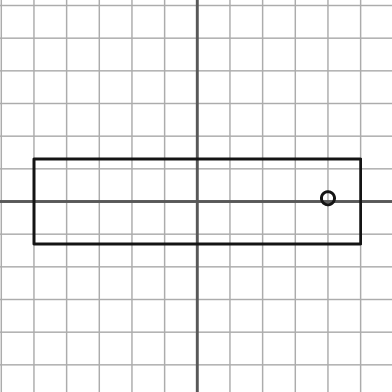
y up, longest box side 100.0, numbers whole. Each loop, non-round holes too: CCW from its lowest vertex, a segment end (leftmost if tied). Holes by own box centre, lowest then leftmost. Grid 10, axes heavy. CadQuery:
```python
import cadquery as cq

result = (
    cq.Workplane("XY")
    .moveTo(-50.0, -13.0)
    .lineTo(50.0, -13.0)
    .lineTo(50.0, 13.0)
    .lineTo(-50.0, 13.0)
    .close()
    .moveTo(40.0, 1.0)
    .circle(2.0)
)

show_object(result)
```